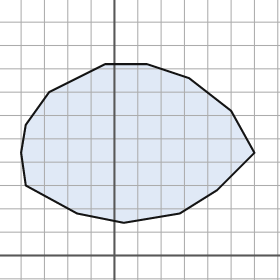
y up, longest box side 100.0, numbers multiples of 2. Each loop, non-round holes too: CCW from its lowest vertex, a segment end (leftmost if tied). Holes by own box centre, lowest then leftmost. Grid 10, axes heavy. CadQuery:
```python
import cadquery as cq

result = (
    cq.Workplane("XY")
    .moveTo(4.0, 14.0)
    .lineTo(28.0, 18.0)
    .lineTo(44.0, 28.0)
    .lineTo(60.0, 44.0)
    .lineTo(50.0, 62.0)
    .lineTo(32.0, 76.0)
    .lineTo(14.0, 82.0)
    .lineTo(-4.0, 82.0)
    .lineTo(-28.0, 70.0)
    .lineTo(-38.0, 56.0)
    .lineTo(-40.0, 44.0)
    .lineTo(-38.0, 30.0)
    .lineTo(-16.0, 18.0)
    .close()
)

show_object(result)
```